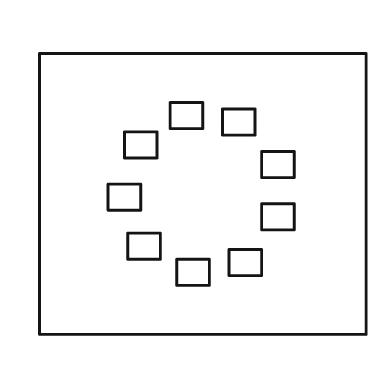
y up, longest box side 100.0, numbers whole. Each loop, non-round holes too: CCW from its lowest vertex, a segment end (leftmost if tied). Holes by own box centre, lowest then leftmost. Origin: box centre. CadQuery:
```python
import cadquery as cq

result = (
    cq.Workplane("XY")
    .moveTo(-50.0, -43.0)
    .lineTo(50.0, -43.0)
    .lineTo(50.0, 43.0)
    .lineTo(-50.0, 43.0)
    .close()
    .moveTo(-8.0, -28.0)
    .lineTo(2.0, -28.0)
    .lineTo(2.0, -20.0)
    .lineTo(-8.0, -20.0)
    .close()
    .moveTo(8.0, -25.0)
    .lineTo(18.0, -25.0)
    .lineTo(18.0, -17.0)
    .lineTo(8.0, -17.0)
    .close()
    .moveTo(-23.0, -20.0)
    .lineTo(-13.0, -20.0)
    .lineTo(-13.0, -12.0)
    .lineTo(-23.0, -12.0)
    .close()
    .moveTo(18.0, -11.0)
    .lineTo(28.0, -11.0)
    .lineTo(28.0, -3.0)
    .lineTo(18.0, -3.0)
    .close()
    .moveTo(-29.0, -5.0)
    .lineTo(-19.0, -5.0)
    .lineTo(-19.0, 3.0)
    .lineTo(-29.0, 3.0)
    .close()
    .moveTo(18.0, 5.0)
    .lineTo(28.0, 5.0)
    .lineTo(28.0, 13.0)
    .lineTo(18.0, 13.0)
    .close()
    .moveTo(-24.0, 11.0)
    .lineTo(-14.0, 11.0)
    .lineTo(-14.0, 19.0)
    .lineTo(-24.0, 19.0)
    .close()
    .moveTo(6.0, 18.0)
    .lineTo(16.0, 18.0)
    .lineTo(16.0, 26.0)
    .lineTo(6.0, 26.0)
    .close()
    .moveTo(-10.0, 20.0)
    .lineTo(0.0, 20.0)
    .lineTo(0.0, 28.0)
    .lineTo(-10.0, 28.0)
    .close()
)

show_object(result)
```